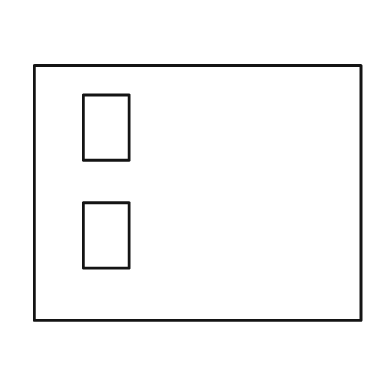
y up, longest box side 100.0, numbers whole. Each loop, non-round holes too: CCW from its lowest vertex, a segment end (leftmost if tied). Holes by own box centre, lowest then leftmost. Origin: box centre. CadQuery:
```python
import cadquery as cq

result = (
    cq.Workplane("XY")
    .moveTo(-50.0, -39.0)
    .lineTo(50.0, -39.0)
    .lineTo(50.0, 39.0)
    .lineTo(-50.0, 39.0)
    .close()
    .moveTo(-35.0, -23.0)
    .lineTo(-21.0, -23.0)
    .lineTo(-21.0, -3.0)
    .lineTo(-35.0, -3.0)
    .close()
    .moveTo(-35.0, 10.0)
    .lineTo(-21.0, 10.0)
    .lineTo(-21.0, 30.0)
    .lineTo(-35.0, 30.0)
    .close()
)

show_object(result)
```